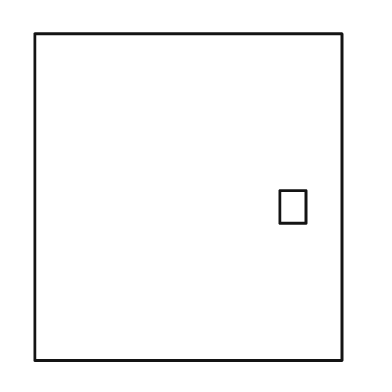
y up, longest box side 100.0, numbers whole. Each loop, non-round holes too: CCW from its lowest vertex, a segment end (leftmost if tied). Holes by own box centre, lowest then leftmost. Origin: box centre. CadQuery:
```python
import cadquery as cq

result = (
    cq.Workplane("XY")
    .moveTo(-47.0, -50.0)
    .lineTo(47.0, -50.0)
    .lineTo(47.0, 50.0)
    .lineTo(-47.0, 50.0)
    .close()
    .moveTo(28.0, -8.0)
    .lineTo(36.0, -8.0)
    .lineTo(36.0, 2.0)
    .lineTo(28.0, 2.0)
    .close()
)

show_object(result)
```